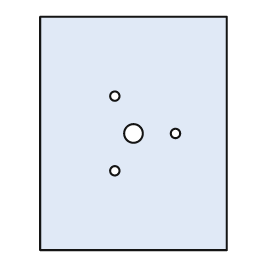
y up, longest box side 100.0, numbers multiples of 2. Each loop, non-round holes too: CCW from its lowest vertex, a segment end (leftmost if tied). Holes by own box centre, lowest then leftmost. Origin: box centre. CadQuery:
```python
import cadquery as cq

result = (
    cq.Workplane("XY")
    .moveTo(-40.0, -50.0)
    .lineTo(40.0, -50.0)
    .lineTo(40.0, 50.0)
    .lineTo(-40.0, 50.0)
    .close()
    .moveTo(-8.0, -16.0)
    .circle(2.0)
    .moveTo(0.0, 0.0)
    .circle(4.0)
    .moveTo(18.0, 0.0)
    .circle(2.0)
    .moveTo(-8.0, 16.0)
    .circle(2.0)
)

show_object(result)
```